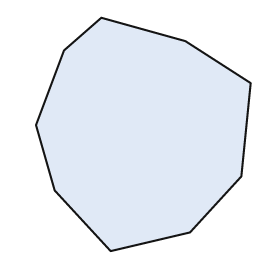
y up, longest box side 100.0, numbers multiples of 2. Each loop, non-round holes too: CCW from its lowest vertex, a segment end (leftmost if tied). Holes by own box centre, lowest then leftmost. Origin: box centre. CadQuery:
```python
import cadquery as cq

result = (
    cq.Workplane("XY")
    .moveTo(-14.0, -50.0)
    .lineTo(20.0, -42.0)
    .lineTo(42.0, -18.0)
    .lineTo(46.0, 22.0)
    .lineTo(18.0, 40.0)
    .lineTo(-18.0, 50.0)
    .lineTo(-34.0, 36.0)
    .lineTo(-46.0, 4.0)
    .lineTo(-38.0, -24.0)
    .close()
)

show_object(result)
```